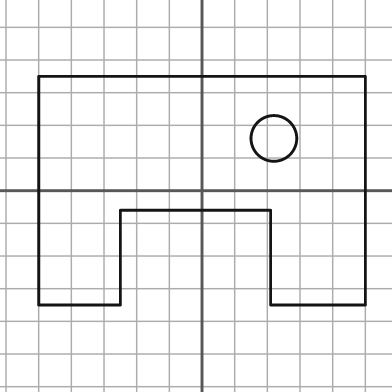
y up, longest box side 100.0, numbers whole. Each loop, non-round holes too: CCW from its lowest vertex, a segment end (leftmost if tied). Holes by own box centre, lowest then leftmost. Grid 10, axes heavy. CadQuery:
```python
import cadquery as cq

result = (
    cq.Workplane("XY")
    .moveTo(-50.0, -35.0)
    .lineTo(-25.0, -35.0)
    .lineTo(-25.0, -6.0)
    .lineTo(21.0, -6.0)
    .lineTo(21.0, -35.0)
    .lineTo(50.0, -35.0)
    .lineTo(50.0, 35.0)
    .lineTo(-50.0, 35.0)
    .close()
    .moveTo(22.0, 16.0)
    .circle(7.0)
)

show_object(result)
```